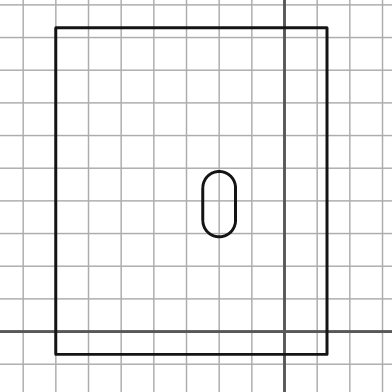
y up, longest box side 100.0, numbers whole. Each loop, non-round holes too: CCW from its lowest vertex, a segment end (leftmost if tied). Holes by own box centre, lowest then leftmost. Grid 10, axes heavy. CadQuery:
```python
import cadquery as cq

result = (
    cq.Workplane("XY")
    .moveTo(-70.0, -7.0)
    .lineTo(13.0, -7.0)
    .lineTo(13.0, 93.0)
    .lineTo(-70.0, 93.0)
    .close()
    .moveTo(-25.0, 34.0)
    .threePointArc((-20.0, 29.0), (-15.0, 34.0))
    .lineTo(-15.0, 44.0)
    .threePointArc((-20.0, 49.0), (-25.0, 44.0))
    .close()
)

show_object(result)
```